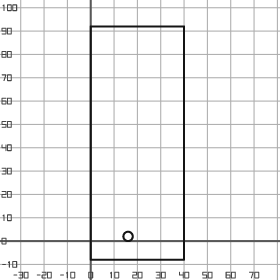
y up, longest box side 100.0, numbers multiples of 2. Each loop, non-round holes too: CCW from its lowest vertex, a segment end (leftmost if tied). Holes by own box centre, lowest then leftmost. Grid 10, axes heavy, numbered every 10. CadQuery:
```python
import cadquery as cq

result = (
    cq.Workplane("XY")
    .moveTo(0.0, -8.0)
    .lineTo(40.0, -8.0)
    .lineTo(40.0, 92.0)
    .lineTo(0.0, 92.0)
    .close()
    .moveTo(16.0, 2.0)
    .circle(2.0)
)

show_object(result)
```